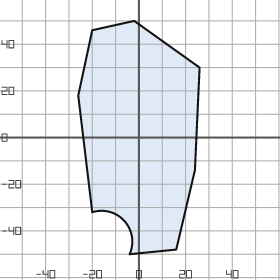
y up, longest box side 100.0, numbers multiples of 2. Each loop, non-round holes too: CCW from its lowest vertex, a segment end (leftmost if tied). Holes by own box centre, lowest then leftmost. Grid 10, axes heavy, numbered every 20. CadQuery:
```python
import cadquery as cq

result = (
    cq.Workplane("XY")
    .moveTo(-4.0, -50.0)
    .lineTo(16.0, -48.0)
    .lineTo(24.0, -14.0)
    .lineTo(26.0, 30.0)
    .lineTo(-2.0, 50.0)
    .lineTo(-20.0, 46.0)
    .lineTo(-26.0, 18.0)
    .lineTo(-20.0, -32.0)
    .threePointArc((-6.0, -36.0), (-4.0, -50.0))
    .close()
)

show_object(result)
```